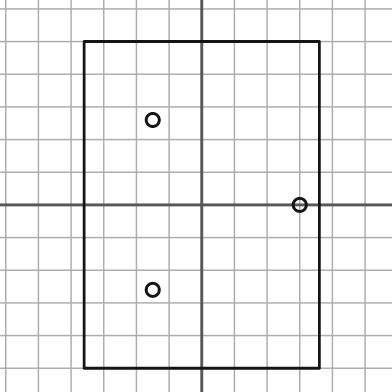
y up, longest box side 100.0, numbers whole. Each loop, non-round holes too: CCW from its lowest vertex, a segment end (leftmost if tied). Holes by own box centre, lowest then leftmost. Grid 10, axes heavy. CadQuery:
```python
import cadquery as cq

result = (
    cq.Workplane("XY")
    .moveTo(-36.0, -50.0)
    .lineTo(36.0, -50.0)
    .lineTo(36.0, 50.0)
    .lineTo(-36.0, 50.0)
    .close()
    .moveTo(-15.0, -26.0)
    .circle(2.0)
    .moveTo(30.0, 0.0)
    .circle(2.0)
    .moveTo(-15.0, 26.0)
    .circle(2.0)
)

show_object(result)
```